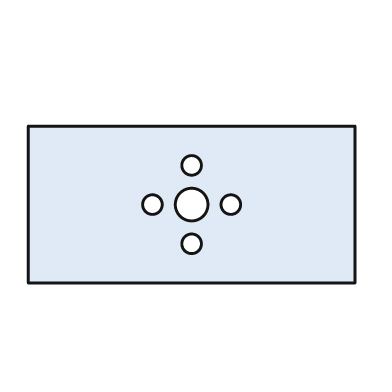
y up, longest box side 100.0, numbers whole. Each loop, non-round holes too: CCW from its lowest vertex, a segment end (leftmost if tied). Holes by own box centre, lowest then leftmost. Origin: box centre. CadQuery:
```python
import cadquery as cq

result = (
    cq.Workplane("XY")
    .moveTo(-50.0, -24.0)
    .lineTo(50.0, -24.0)
    .lineTo(50.0, 24.0)
    .lineTo(-50.0, 24.0)
    .close()
    .moveTo(0.0, -12.0)
    .circle(3.0)
    .moveTo(-12.0, 0.0)
    .circle(3.0)
    .moveTo(0.0, 0.0)
    .circle(5.0)
    .moveTo(12.0, 0.0)
    .circle(3.0)
    .moveTo(0.0, 12.0)
    .circle(3.0)
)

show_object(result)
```